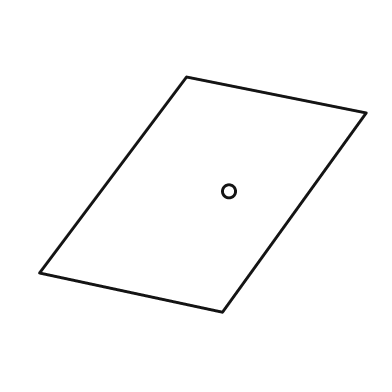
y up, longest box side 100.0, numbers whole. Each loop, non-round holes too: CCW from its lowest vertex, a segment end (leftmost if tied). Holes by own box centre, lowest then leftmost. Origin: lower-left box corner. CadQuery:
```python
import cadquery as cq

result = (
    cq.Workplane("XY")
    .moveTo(56.0, 0.0)
    .lineTo(100.0, 61.0)
    .lineTo(45.0, 72.0)
    .lineTo(0.0, 12.0)
    .close()
    .moveTo(58.0, 37.0)
    .circle(2.0)
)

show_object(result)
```